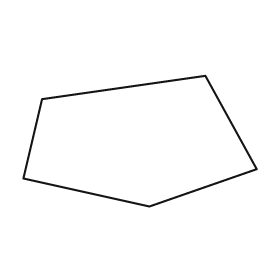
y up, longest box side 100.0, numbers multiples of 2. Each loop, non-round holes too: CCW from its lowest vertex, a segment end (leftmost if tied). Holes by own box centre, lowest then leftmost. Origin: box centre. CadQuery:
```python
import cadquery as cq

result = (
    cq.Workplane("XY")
    .moveTo(4.0, -28.0)
    .lineTo(50.0, -12.0)
    .lineTo(28.0, 28.0)
    .lineTo(-42.0, 18.0)
    .lineTo(-50.0, -16.0)
    .close()
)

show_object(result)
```